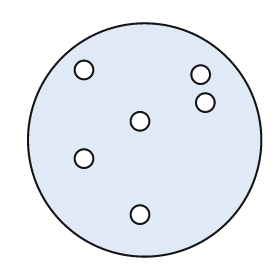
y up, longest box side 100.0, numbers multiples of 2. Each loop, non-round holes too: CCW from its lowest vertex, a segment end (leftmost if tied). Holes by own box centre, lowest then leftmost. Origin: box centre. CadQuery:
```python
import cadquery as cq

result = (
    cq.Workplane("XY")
    .moveTo(0.0, 0.0)
    .circle(50.0)
    .moveTo(-2.0, -32.0)
    .circle(4.0)
    .moveTo(-26.0, -8.0)
    .circle(4.0)
    .moveTo(-2.0, 8.0)
    .circle(4.0)
    .moveTo(26.0, 16.0)
    .circle(4.0)
    .moveTo(24.0, 28.0)
    .circle(4.0)
    .moveTo(-26.0, 30.0)
    .circle(4.0)
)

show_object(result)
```